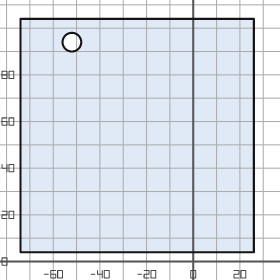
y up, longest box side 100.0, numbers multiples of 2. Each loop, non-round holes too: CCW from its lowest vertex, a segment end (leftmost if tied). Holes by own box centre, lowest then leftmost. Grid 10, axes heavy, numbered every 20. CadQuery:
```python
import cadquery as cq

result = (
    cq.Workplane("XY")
    .moveTo(-74.0, 4.0)
    .lineTo(26.0, 4.0)
    .lineTo(26.0, 104.0)
    .lineTo(-74.0, 104.0)
    .close()
    .moveTo(-52.0, 94.0)
    .circle(4.0)
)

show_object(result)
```